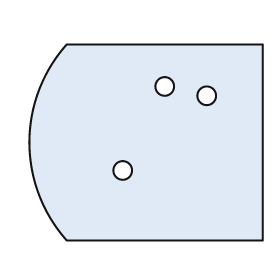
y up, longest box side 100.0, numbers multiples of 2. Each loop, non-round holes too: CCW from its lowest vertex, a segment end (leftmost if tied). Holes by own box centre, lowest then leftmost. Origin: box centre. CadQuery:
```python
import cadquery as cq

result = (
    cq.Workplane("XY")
    .moveTo(-34.0, -42.0)
    .lineTo(50.0, -42.0)
    .lineTo(50.0, 42.0)
    .lineTo(-34.0, 42.0)
    .threePointArc((-50.0, 0.0), (-34.0, -42.0))
    .close()
    .moveTo(-10.0, -12.0)
    .circle(4.0)
    .moveTo(26.0, 20.0)
    .circle(4.0)
    .moveTo(8.0, 24.0)
    .circle(4.0)
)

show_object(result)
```